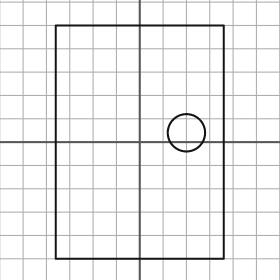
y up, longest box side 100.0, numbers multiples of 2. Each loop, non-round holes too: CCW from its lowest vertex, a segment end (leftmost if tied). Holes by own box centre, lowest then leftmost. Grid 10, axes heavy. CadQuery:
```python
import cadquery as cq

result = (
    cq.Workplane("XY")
    .moveTo(-36.0, -50.0)
    .lineTo(36.0, -50.0)
    .lineTo(36.0, 50.0)
    .lineTo(-36.0, 50.0)
    .close()
    .moveTo(20.0, 4.0)
    .circle(8.0)
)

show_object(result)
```